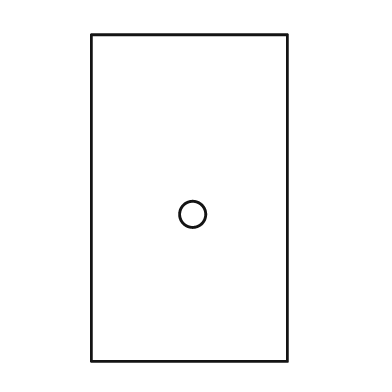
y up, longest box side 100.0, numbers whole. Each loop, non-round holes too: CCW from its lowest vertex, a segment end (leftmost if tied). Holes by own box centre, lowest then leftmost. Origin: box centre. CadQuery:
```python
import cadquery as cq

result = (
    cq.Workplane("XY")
    .moveTo(-30.0, -50.0)
    .lineTo(30.0, -50.0)
    .lineTo(30.0, 50.0)
    .lineTo(-30.0, 50.0)
    .close()
    .moveTo(1.0, -5.0)
    .circle(4.0)
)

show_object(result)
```